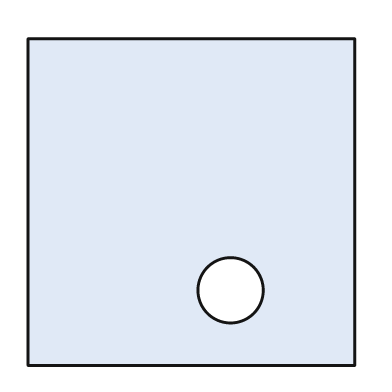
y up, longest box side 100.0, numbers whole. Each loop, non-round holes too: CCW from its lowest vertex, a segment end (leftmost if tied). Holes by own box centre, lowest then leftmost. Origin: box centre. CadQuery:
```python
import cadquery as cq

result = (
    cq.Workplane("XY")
    .moveTo(-50.0, -50.0)
    .lineTo(50.0, -50.0)
    .lineTo(50.0, 50.0)
    .lineTo(-50.0, 50.0)
    .close()
    .moveTo(12.0, -27.0)
    .circle(10.0)
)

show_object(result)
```